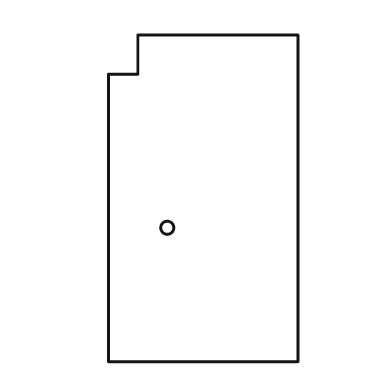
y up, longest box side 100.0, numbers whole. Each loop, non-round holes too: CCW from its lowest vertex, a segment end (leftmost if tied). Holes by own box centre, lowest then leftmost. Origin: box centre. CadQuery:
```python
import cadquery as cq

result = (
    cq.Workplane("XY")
    .moveTo(-29.0, -50.0)
    .lineTo(29.0, -50.0)
    .lineTo(29.0, 50.0)
    .lineTo(-20.0, 50.0)
    .lineTo(-20.0, 38.0)
    .lineTo(-29.0, 38.0)
    .close()
    .moveTo(-11.0, -9.0)
    .circle(2.0)
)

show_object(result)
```